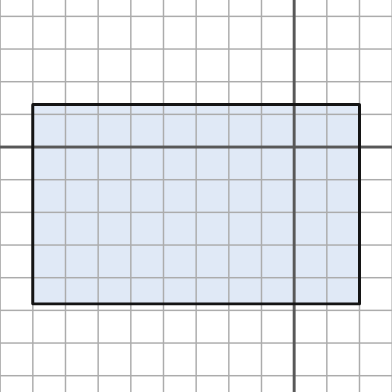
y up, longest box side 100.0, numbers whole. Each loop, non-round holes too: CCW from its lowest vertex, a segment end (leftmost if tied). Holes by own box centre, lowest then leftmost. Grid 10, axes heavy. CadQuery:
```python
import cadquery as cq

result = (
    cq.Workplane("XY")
    .moveTo(-80.0, -48.0)
    .lineTo(20.0, -48.0)
    .lineTo(20.0, 13.0)
    .lineTo(-80.0, 13.0)
    .close()
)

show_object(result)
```